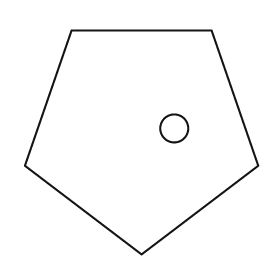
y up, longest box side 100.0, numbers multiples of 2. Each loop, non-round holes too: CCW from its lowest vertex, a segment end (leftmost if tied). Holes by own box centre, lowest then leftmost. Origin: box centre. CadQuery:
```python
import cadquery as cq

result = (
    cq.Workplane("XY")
    .moveTo(0.0, -48.0)
    .lineTo(50.0, -10.0)
    .lineTo(30.0, 48.0)
    .lineTo(-30.0, 48.0)
    .lineTo(-50.0, -10.0)
    .close()
    .moveTo(14.0, 6.0)
    .circle(6.0)
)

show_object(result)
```